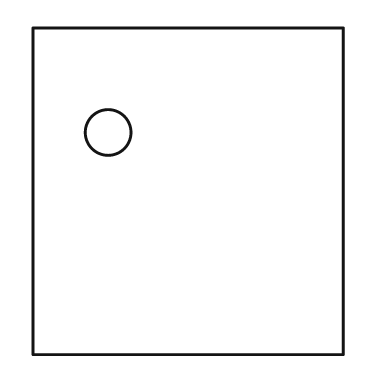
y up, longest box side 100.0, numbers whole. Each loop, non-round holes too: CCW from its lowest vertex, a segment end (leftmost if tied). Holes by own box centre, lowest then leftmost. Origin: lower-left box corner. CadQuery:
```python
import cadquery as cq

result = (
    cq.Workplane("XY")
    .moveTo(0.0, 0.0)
    .lineTo(95.0, 0.0)
    .lineTo(95.0, 100.0)
    .lineTo(0.0, 100.0)
    .close()
    .moveTo(23.0, 68.0)
    .circle(7.0)
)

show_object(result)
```